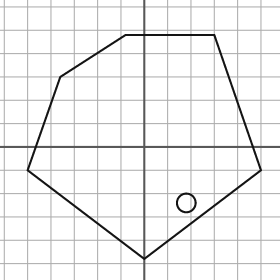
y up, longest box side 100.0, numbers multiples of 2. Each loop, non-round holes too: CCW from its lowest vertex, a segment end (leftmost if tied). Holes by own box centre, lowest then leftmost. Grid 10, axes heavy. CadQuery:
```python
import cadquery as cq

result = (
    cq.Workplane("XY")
    .moveTo(0.0, -48.0)
    .lineTo(50.0, -10.0)
    .lineTo(30.0, 48.0)
    .lineTo(-8.0, 48.0)
    .lineTo(-36.0, 30.0)
    .lineTo(-50.0, -10.0)
    .close()
    .moveTo(18.0, -24.0)
    .circle(4.0)
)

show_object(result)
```